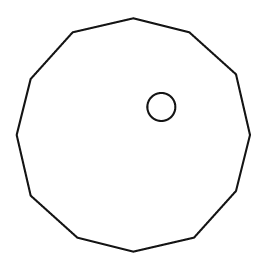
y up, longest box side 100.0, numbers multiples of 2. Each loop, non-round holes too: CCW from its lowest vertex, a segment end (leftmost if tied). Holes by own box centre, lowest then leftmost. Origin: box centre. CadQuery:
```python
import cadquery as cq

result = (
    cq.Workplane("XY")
    .moveTo(0.0, -50.0)
    .lineTo(26.0, -44.0)
    .lineTo(44.0, -24.0)
    .lineTo(50.0, 0.0)
    .lineTo(44.0, 26.0)
    .lineTo(24.0, 44.0)
    .lineTo(0.0, 50.0)
    .lineTo(-26.0, 44.0)
    .lineTo(-44.0, 24.0)
    .lineTo(-50.0, 0.0)
    .lineTo(-44.0, -26.0)
    .lineTo(-24.0, -44.0)
    .close()
    .moveTo(12.0, 12.0)
    .circle(6.0)
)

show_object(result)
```